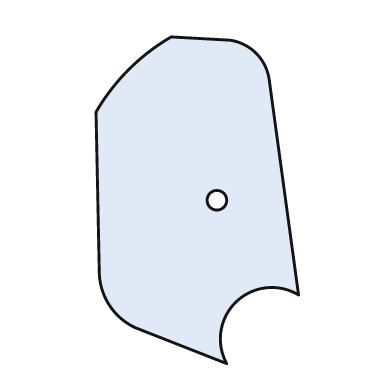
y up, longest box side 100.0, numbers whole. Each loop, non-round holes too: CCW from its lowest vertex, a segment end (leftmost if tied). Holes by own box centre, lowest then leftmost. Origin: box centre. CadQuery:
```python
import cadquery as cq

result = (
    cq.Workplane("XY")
    .moveTo(9.0, -50.0)
    .threePointArc((12.0, -31.0), (31.0, -29.0))
    .lineTo(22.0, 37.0)
    .threePointArc((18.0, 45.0), (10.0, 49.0))
    .lineTo(-8.0, 50.0)
    .threePointArc((-21.0, 40.0), (-31.0, 27.0))
    .lineTo(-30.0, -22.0)
    .threePointArc((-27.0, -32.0), (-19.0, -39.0))
    .close()
    .moveTo(6.0, 0.0)
    .circle(3.0)
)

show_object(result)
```